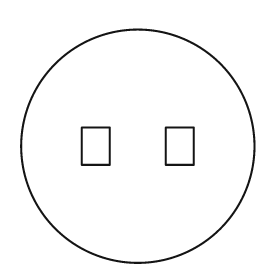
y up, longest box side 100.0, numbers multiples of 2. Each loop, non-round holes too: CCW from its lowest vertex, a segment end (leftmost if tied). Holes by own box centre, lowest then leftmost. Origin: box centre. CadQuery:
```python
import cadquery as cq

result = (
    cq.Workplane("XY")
    .moveTo(0.0, 0.0)
    .circle(50.0)
    .moveTo(-24.0, -8.0)
    .lineTo(-12.0, -8.0)
    .lineTo(-12.0, 8.0)
    .lineTo(-24.0, 8.0)
    .close()
    .moveTo(12.0, -8.0)
    .lineTo(24.0, -8.0)
    .lineTo(24.0, 8.0)
    .lineTo(12.0, 8.0)
    .close()
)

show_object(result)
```